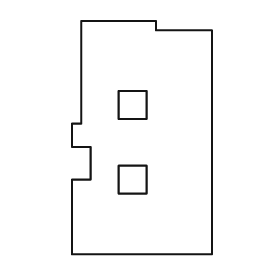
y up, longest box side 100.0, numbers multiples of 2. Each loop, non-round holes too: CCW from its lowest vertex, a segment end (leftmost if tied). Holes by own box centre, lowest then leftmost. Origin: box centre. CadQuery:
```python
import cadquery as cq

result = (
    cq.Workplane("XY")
    .moveTo(-30.0, -50.0)
    .lineTo(30.0, -50.0)
    .lineTo(30.0, 46.0)
    .lineTo(6.0, 46.0)
    .lineTo(6.0, 50.0)
    .lineTo(-26.0, 50.0)
    .lineTo(-26.0, 6.0)
    .lineTo(-30.0, 6.0)
    .lineTo(-30.0, -4.0)
    .lineTo(-22.0, -4.0)
    .lineTo(-22.0, -18.0)
    .lineTo(-30.0, -18.0)
    .close()
    .moveTo(-10.0, -24.0)
    .lineTo(2.0, -24.0)
    .lineTo(2.0, -12.0)
    .lineTo(-10.0, -12.0)
    .close()
    .moveTo(-10.0, 8.0)
    .lineTo(2.0, 8.0)
    .lineTo(2.0, 20.0)
    .lineTo(-10.0, 20.0)
    .close()
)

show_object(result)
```